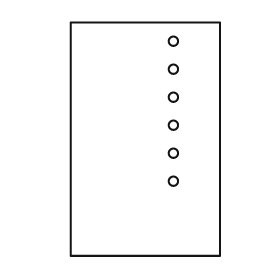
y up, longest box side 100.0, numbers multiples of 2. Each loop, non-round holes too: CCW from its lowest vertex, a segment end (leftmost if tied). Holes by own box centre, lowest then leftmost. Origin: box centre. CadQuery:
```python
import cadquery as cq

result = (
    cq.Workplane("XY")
    .moveTo(-32.0, -50.0)
    .lineTo(32.0, -50.0)
    .lineTo(32.0, 50.0)
    .lineTo(-32.0, 50.0)
    .close()
    .moveTo(12.0, -18.0)
    .circle(2.0)
    .moveTo(12.0, -6.0)
    .circle(2.0)
    .moveTo(12.0, 6.0)
    .circle(2.0)
    .moveTo(12.0, 18.0)
    .circle(2.0)
    .moveTo(12.0, 30.0)
    .circle(2.0)
    .moveTo(12.0, 42.0)
    .circle(2.0)
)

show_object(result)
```